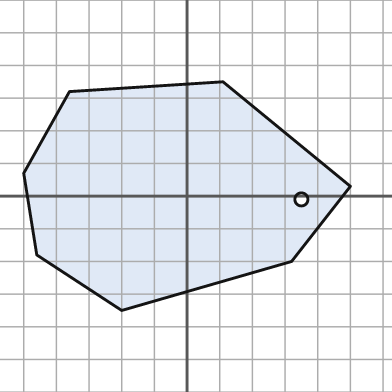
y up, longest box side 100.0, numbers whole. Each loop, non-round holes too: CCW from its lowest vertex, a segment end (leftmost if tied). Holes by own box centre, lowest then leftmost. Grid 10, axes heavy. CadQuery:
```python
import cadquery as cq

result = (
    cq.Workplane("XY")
    .moveTo(-20.0, -35.0)
    .lineTo(32.0, -20.0)
    .lineTo(50.0, 3.0)
    .lineTo(11.0, 35.0)
    .lineTo(-36.0, 32.0)
    .lineTo(-50.0, 7.0)
    .lineTo(-46.0, -18.0)
    .close()
    .moveTo(35.0, -1.0)
    .circle(2.0)
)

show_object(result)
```